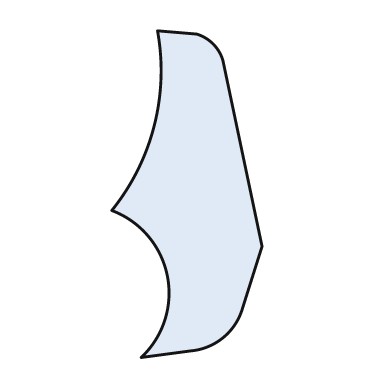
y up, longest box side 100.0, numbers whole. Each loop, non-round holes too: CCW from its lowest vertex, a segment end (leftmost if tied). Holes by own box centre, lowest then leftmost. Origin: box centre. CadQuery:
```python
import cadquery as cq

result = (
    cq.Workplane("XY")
    .moveTo(-14.0, -50.0)
    .lineTo(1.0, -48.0)
    .threePointArc((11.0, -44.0), (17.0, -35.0))
    .lineTo(23.0, -16.0)
    .lineTo(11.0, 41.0)
    .threePointArc((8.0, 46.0), (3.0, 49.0))
    .lineTo(-9.0, 50.0)
    .threePointArc((-10.0, 21.0), (-23.0, -5.0))
    .threePointArc((-6.0, -25.0), (-14.0, -50.0))
    .close()
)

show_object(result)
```